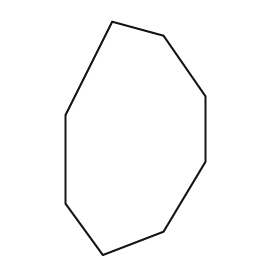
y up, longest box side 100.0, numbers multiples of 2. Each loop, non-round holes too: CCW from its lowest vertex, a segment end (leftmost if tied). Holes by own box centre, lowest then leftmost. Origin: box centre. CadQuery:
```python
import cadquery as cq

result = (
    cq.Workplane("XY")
    .moveTo(-14.0, -50.0)
    .lineTo(12.0, -40.0)
    .lineTo(30.0, -10.0)
    .lineTo(30.0, 18.0)
    .lineTo(12.0, 44.0)
    .lineTo(-10.0, 50.0)
    .lineTo(-30.0, 10.0)
    .lineTo(-30.0, -28.0)
    .close()
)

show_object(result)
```